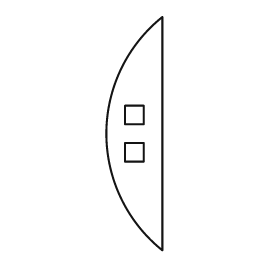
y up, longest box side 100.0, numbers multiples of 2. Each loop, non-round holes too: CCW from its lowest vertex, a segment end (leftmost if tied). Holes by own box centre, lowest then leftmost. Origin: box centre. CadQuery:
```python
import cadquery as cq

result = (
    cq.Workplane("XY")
    .moveTo(12.0, -50.0)
    .lineTo(12.0, 50.0)
    .threePointArc((-12.0, 0.0), (12.0, -50.0))
    .close()
    .moveTo(-4.0, -12.0)
    .lineTo(4.0, -12.0)
    .lineTo(4.0, -4.0)
    .lineTo(-4.0, -4.0)
    .close()
    .moveTo(-4.0, 4.0)
    .lineTo(4.0, 4.0)
    .lineTo(4.0, 12.0)
    .lineTo(-4.0, 12.0)
    .close()
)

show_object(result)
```